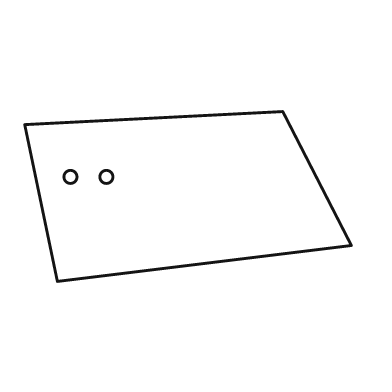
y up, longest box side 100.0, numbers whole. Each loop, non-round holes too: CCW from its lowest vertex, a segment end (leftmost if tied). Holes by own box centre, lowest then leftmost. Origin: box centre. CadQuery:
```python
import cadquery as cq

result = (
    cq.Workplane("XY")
    .moveTo(-40.0, -26.0)
    .lineTo(50.0, -15.0)
    .lineTo(29.0, 26.0)
    .lineTo(-50.0, 22.0)
    .close()
    .moveTo(-36.0, 6.0)
    .circle(2.0)
    .moveTo(-25.0, 6.0)
    .circle(2.0)
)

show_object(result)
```